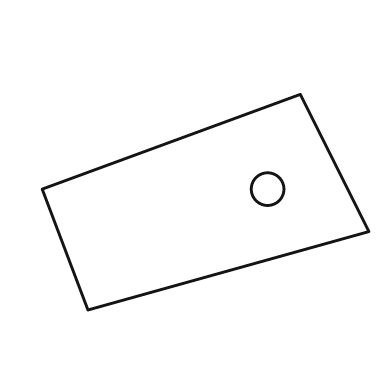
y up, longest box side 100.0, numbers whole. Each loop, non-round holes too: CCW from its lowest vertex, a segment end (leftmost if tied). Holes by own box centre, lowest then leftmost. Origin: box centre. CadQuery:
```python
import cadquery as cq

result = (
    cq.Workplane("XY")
    .moveTo(-36.0, -33.0)
    .lineTo(50.0, -9.0)
    .lineTo(29.0, 33.0)
    .lineTo(-50.0, 4.0)
    .close()
    .moveTo(19.0, 4.0)
    .circle(5.0)
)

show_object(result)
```